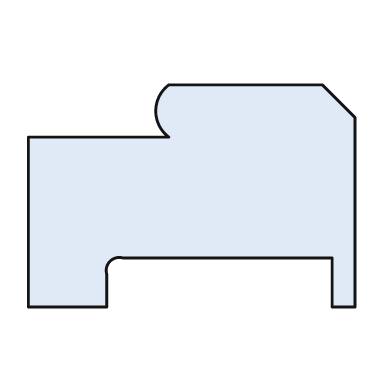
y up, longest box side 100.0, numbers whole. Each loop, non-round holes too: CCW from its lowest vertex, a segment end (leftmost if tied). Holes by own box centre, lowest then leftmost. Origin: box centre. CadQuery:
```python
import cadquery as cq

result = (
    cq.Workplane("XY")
    .moveTo(-50.0, -34.0)
    .lineTo(-26.0, -34.0)
    .lineTo(-26.0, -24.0)
    .threePointArc((-25.0, -20.0), (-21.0, -19.0))
    .lineTo(43.0, -19.0)
    .lineTo(43.0, -34.0)
    .lineTo(50.0, -34.0)
    .lineTo(50.0, 24.0)
    .lineTo(40.0, 34.0)
    .lineTo(-7.0, 34.0)
    .threePointArc((-11.0, 26.0), (-7.0, 18.0))
    .lineTo(-50.0, 18.0)
    .close()
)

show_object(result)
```